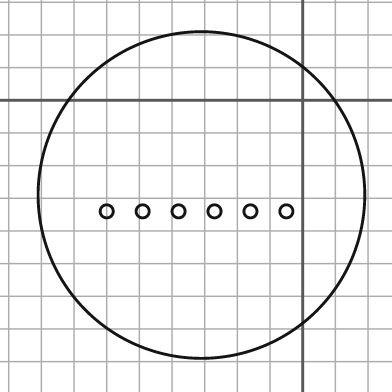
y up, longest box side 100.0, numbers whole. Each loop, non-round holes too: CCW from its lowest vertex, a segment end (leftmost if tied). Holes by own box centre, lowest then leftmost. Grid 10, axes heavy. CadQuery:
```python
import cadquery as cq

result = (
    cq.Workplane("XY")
    .moveTo(-31.0, -29.0)
    .circle(50.0)
    .moveTo(-60.0, -34.0)
    .circle(2.0)
    .moveTo(-49.0, -34.0)
    .circle(2.0)
    .moveTo(-38.0, -34.0)
    .circle(2.0)
    .moveTo(-27.0, -34.0)
    .circle(2.0)
    .moveTo(-16.0, -34.0)
    .circle(2.0)
    .moveTo(-5.0, -34.0)
    .circle(2.0)
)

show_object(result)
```